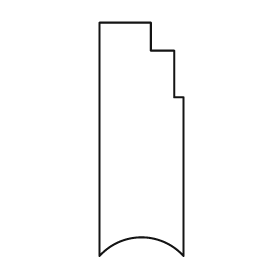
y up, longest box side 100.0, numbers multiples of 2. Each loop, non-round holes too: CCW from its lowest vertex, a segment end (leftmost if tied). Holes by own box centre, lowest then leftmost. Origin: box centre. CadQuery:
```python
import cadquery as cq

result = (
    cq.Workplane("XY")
    .moveTo(-18.0, -50.0)
    .threePointArc((0.0, -42.0), (18.0, -50.0))
    .lineTo(18.0, 18.0)
    .lineTo(14.0, 18.0)
    .lineTo(14.0, 38.0)
    .lineTo(4.0, 38.0)
    .lineTo(4.0, 50.0)
    .lineTo(-18.0, 50.0)
    .close()
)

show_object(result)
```